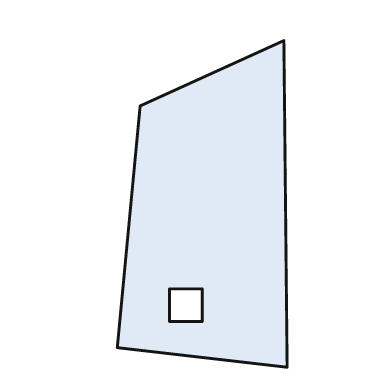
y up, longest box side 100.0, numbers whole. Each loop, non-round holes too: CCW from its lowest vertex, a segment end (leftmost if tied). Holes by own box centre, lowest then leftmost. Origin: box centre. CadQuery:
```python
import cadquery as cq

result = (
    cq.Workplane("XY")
    .moveTo(26.0, -50.0)
    .lineTo(25.0, 50.0)
    .lineTo(-19.0, 30.0)
    .lineTo(-26.0, -44.0)
    .close()
    .moveTo(-10.0, -36.0)
    .lineTo(0.0, -36.0)
    .lineTo(0.0, -26.0)
    .lineTo(-10.0, -26.0)
    .close()
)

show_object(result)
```